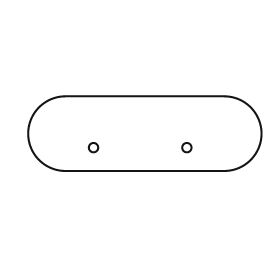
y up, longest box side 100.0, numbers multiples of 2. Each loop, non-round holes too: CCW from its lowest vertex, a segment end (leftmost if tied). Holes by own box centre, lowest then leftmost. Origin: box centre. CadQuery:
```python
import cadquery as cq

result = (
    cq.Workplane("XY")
    .moveTo(-34.0, -16.0)
    .lineTo(34.0, -16.0)
    .threePointArc((50.0, 0.0), (34.0, 16.0))
    .lineTo(-34.0, 16.0)
    .threePointArc((-50.0, 0.0), (-34.0, -16.0))
    .close()
    .moveTo(-22.0, -6.0)
    .circle(2.0)
    .moveTo(18.0, -6.0)
    .circle(2.0)
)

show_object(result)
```